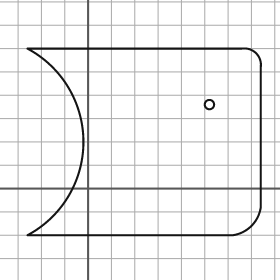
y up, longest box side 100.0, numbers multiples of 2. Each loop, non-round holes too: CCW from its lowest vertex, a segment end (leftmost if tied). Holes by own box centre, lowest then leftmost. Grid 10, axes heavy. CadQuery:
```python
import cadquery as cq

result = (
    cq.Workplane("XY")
    .moveTo(-26.0, -20.0)
    .lineTo(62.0, -20.0)
    .threePointArc((70.0, -16.0), (74.0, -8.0))
    .lineTo(74.0, 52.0)
    .threePointArc((72.0, 58.0), (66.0, 60.0))
    .lineTo(-26.0, 60.0)
    .threePointArc((-2.0, 20.0), (-26.0, -20.0))
    .close()
    .moveTo(52.0, 36.0)
    .circle(2.0)
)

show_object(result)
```